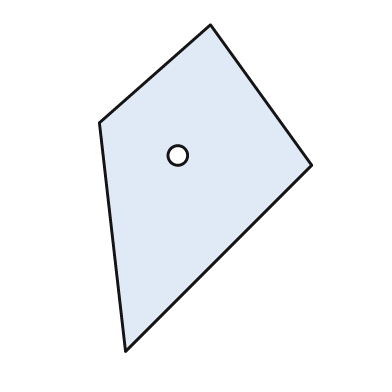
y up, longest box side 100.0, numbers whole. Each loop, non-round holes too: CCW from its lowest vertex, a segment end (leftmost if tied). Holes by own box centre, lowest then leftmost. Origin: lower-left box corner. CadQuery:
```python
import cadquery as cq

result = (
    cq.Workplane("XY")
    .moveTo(8.0, 0.0)
    .lineTo(65.0, 57.0)
    .lineTo(34.0, 100.0)
    .lineTo(0.0, 70.0)
    .close()
    .moveTo(24.0, 60.0)
    .circle(3.0)
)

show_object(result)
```